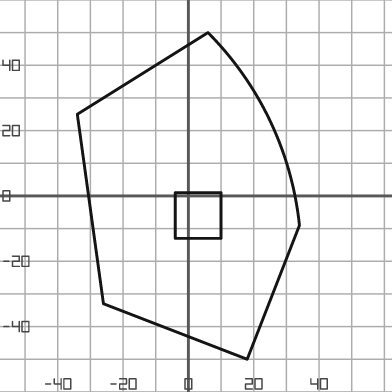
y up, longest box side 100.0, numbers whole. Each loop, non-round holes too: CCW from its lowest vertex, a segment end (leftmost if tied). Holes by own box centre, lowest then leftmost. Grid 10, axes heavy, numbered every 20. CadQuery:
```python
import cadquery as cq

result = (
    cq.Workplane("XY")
    .moveTo(18.0, -50.0)
    .lineTo(34.0, -9.0)
    .threePointArc((25.0, 23.0), (6.0, 50.0))
    .lineTo(-34.0, 25.0)
    .lineTo(-26.0, -33.0)
    .close()
    .moveTo(-4.0, -13.0)
    .lineTo(10.0, -13.0)
    .lineTo(10.0, 1.0)
    .lineTo(-4.0, 1.0)
    .close()
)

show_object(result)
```